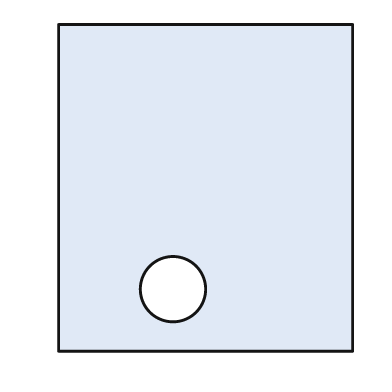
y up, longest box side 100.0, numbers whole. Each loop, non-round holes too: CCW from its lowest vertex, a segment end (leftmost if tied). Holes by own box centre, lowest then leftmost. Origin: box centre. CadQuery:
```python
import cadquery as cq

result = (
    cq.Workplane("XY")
    .moveTo(-45.0, -50.0)
    .lineTo(45.0, -50.0)
    .lineTo(45.0, 50.0)
    .lineTo(-45.0, 50.0)
    .close()
    .moveTo(-10.0, -31.0)
    .circle(10.0)
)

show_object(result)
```